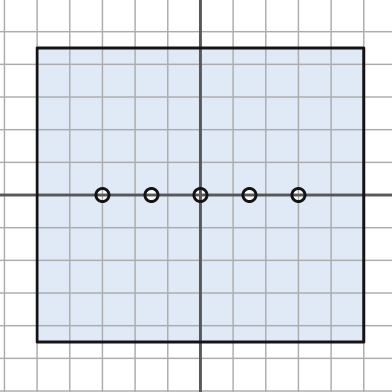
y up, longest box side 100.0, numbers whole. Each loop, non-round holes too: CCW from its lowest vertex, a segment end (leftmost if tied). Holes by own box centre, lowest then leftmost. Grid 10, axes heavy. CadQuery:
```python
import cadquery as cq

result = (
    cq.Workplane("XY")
    .moveTo(-50.0, -45.0)
    .lineTo(50.0, -45.0)
    .lineTo(50.0, 45.0)
    .lineTo(-50.0, 45.0)
    .close()
    .moveTo(-30.0, 0.0)
    .circle(2.0)
    .moveTo(-15.0, 0.0)
    .circle(2.0)
    .moveTo(0.0, 0.0)
    .circle(2.0)
    .moveTo(15.0, 0.0)
    .circle(2.0)
    .moveTo(30.0, 0.0)
    .circle(2.0)
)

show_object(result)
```